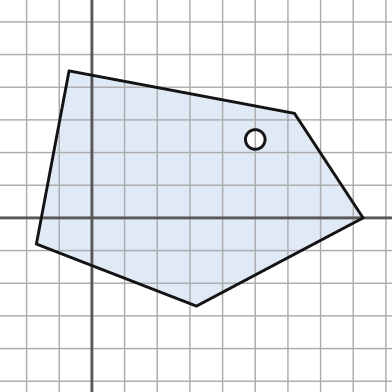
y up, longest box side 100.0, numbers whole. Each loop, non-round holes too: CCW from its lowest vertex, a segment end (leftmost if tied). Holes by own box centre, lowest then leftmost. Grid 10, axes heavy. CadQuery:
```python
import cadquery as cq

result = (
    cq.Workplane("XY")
    .moveTo(32.0, -27.0)
    .lineTo(83.0, 0.0)
    .lineTo(62.0, 32.0)
    .lineTo(-7.0, 45.0)
    .lineTo(-17.0, -8.0)
    .close()
    .moveTo(50.0, 24.0)
    .circle(3.0)
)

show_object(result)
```